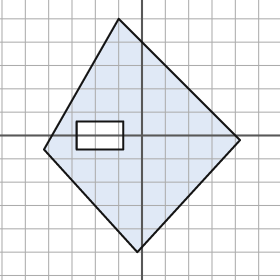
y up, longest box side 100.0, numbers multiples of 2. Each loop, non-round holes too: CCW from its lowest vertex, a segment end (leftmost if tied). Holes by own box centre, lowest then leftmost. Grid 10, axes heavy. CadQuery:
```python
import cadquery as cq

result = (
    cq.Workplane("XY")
    .moveTo(-2.0, -50.0)
    .lineTo(42.0, -2.0)
    .lineTo(-10.0, 50.0)
    .lineTo(-42.0, -6.0)
    .close()
    .moveTo(-28.0, -6.0)
    .lineTo(-8.0, -6.0)
    .lineTo(-8.0, 6.0)
    .lineTo(-28.0, 6.0)
    .close()
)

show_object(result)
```